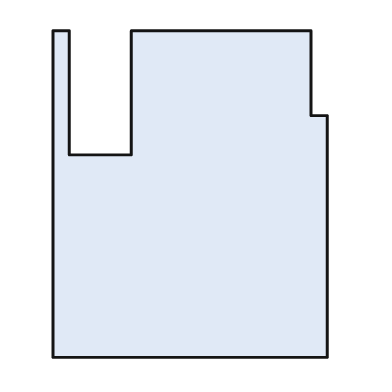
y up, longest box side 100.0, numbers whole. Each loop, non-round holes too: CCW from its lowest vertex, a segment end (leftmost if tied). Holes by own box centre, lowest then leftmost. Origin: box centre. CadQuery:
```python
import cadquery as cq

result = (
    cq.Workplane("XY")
    .moveTo(-42.0, -50.0)
    .lineTo(42.0, -50.0)
    .lineTo(42.0, 24.0)
    .lineTo(37.0, 24.0)
    .lineTo(37.0, 50.0)
    .lineTo(-18.0, 50.0)
    .lineTo(-18.0, 12.0)
    .lineTo(-37.0, 12.0)
    .lineTo(-37.0, 50.0)
    .lineTo(-42.0, 50.0)
    .close()
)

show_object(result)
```